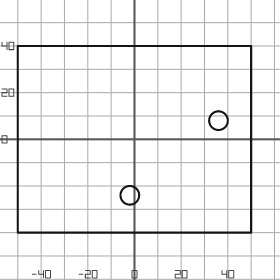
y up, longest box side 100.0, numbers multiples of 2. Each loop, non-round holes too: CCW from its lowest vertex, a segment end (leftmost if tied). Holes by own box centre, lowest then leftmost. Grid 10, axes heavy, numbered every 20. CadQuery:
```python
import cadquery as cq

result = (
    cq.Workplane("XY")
    .moveTo(-50.0, -40.0)
    .lineTo(50.0, -40.0)
    .lineTo(50.0, 40.0)
    .lineTo(-50.0, 40.0)
    .close()
    .moveTo(-2.0, -24.0)
    .circle(4.0)
    .moveTo(36.0, 8.0)
    .circle(4.0)
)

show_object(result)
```